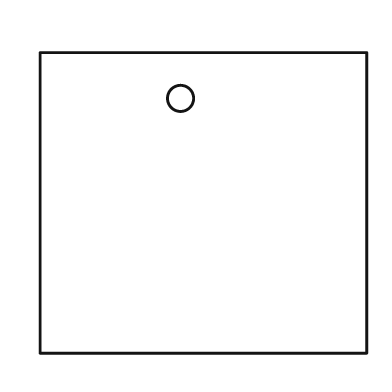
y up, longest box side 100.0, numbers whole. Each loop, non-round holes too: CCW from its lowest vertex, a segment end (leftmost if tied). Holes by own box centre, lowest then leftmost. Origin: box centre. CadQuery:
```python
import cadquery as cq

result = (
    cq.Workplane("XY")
    .moveTo(-50.0, -46.0)
    .lineTo(50.0, -46.0)
    .lineTo(50.0, 46.0)
    .lineTo(-50.0, 46.0)
    .close()
    .moveTo(-7.0, 32.0)
    .circle(4.0)
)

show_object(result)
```